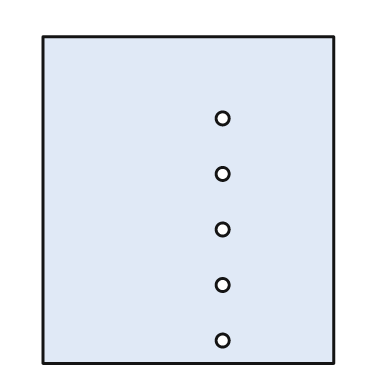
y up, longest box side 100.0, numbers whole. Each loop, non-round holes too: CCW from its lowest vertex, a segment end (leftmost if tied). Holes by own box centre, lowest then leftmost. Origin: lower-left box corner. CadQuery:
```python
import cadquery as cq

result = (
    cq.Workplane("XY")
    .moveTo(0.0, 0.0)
    .lineTo(89.0, 0.0)
    .lineTo(89.0, 100.0)
    .lineTo(0.0, 100.0)
    .close()
    .moveTo(55.0, 7.0)
    .circle(2.0)
    .moveTo(55.0, 24.0)
    .circle(2.0)
    .moveTo(55.0, 41.0)
    .circle(2.0)
    .moveTo(55.0, 58.0)
    .circle(2.0)
    .moveTo(55.0, 75.0)
    .circle(2.0)
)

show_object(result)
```